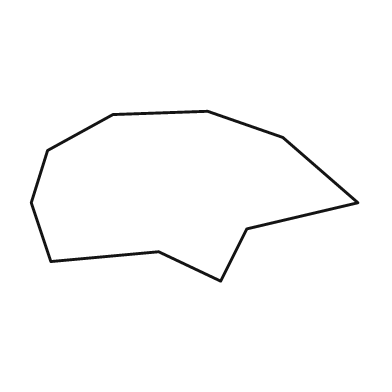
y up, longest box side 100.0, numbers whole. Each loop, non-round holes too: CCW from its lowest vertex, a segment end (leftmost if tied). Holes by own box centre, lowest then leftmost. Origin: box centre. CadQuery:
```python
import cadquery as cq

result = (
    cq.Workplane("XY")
    .moveTo(8.0, -26.0)
    .lineTo(16.0, -10.0)
    .lineTo(50.0, -2.0)
    .lineTo(27.0, 18.0)
    .lineTo(4.0, 26.0)
    .lineTo(-25.0, 25.0)
    .lineTo(-45.0, 14.0)
    .lineTo(-50.0, -2.0)
    .lineTo(-44.0, -20.0)
    .lineTo(-11.0, -17.0)
    .close()
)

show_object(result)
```